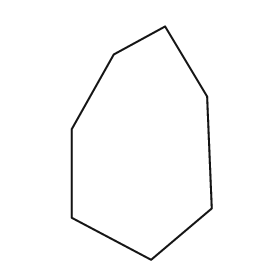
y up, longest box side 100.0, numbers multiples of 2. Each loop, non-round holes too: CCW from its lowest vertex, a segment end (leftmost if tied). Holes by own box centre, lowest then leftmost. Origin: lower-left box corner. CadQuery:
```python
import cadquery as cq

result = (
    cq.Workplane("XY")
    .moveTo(34.0, 0.0)
    .lineTo(60.0, 22.0)
    .lineTo(58.0, 70.0)
    .lineTo(40.0, 100.0)
    .lineTo(18.0, 88.0)
    .lineTo(0.0, 56.0)
    .lineTo(0.0, 18.0)
    .close()
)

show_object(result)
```